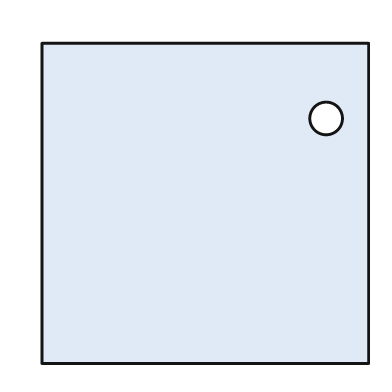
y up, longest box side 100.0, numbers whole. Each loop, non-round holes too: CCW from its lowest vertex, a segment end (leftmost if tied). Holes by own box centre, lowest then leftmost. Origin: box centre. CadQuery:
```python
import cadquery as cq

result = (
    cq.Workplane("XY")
    .moveTo(-50.0, -49.0)
    .lineTo(50.0, -49.0)
    .lineTo(50.0, 49.0)
    .lineTo(-50.0, 49.0)
    .close()
    .moveTo(37.0, 26.0)
    .circle(5.0)
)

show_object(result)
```